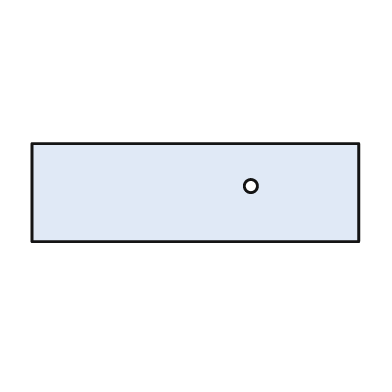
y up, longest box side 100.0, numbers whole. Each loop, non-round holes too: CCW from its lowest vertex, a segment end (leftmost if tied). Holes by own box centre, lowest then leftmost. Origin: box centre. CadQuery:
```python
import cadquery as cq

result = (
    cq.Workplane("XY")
    .moveTo(-50.0, -15.0)
    .lineTo(50.0, -15.0)
    .lineTo(50.0, 15.0)
    .lineTo(-50.0, 15.0)
    .close()
    .moveTo(17.0, 2.0)
    .circle(2.0)
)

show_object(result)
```